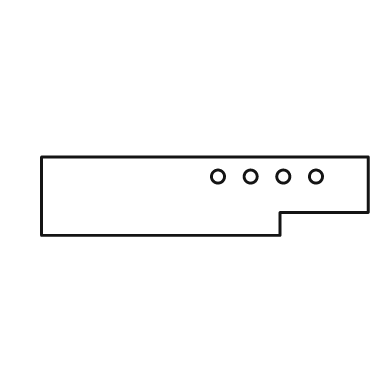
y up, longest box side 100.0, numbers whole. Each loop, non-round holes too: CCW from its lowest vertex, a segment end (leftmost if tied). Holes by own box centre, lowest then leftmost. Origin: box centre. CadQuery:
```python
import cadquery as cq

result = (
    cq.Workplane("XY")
    .moveTo(-50.0, -12.0)
    .lineTo(23.0, -12.0)
    .lineTo(23.0, -5.0)
    .lineTo(50.0, -5.0)
    .lineTo(50.0, 12.0)
    .lineTo(-50.0, 12.0)
    .close()
    .moveTo(4.0, 6.0)
    .circle(2.0)
    .moveTo(14.0, 6.0)
    .circle(2.0)
    .moveTo(24.0, 6.0)
    .circle(2.0)
    .moveTo(34.0, 6.0)
    .circle(2.0)
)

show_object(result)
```